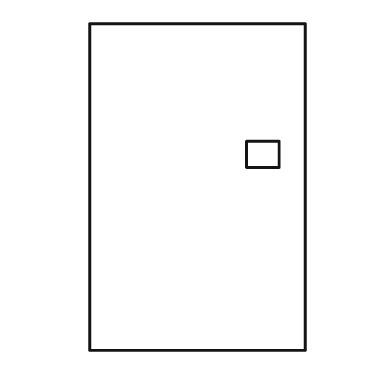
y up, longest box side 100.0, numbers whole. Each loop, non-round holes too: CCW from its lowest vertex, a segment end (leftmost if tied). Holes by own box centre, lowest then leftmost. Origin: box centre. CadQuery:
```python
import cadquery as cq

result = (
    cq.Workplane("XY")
    .moveTo(-33.0, -50.0)
    .lineTo(33.0, -50.0)
    .lineTo(33.0, 50.0)
    .lineTo(-33.0, 50.0)
    .close()
    .moveTo(15.0, 6.0)
    .lineTo(25.0, 6.0)
    .lineTo(25.0, 14.0)
    .lineTo(15.0, 14.0)
    .close()
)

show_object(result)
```